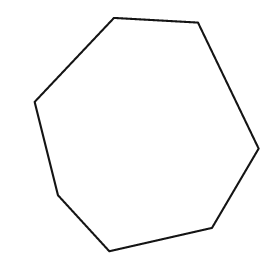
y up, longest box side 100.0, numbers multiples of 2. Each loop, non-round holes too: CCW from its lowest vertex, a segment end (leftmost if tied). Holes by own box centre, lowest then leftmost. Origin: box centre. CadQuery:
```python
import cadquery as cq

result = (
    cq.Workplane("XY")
    .moveTo(-16.0, -50.0)
    .lineTo(28.0, -40.0)
    .lineTo(48.0, -6.0)
    .lineTo(22.0, 48.0)
    .lineTo(-14.0, 50.0)
    .lineTo(-48.0, 14.0)
    .lineTo(-38.0, -26.0)
    .close()
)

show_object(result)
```